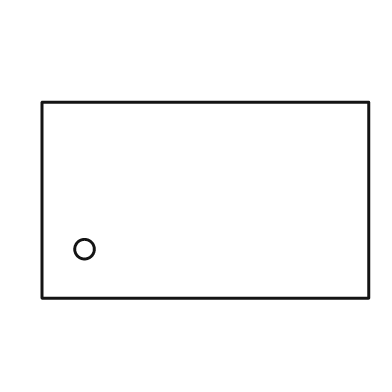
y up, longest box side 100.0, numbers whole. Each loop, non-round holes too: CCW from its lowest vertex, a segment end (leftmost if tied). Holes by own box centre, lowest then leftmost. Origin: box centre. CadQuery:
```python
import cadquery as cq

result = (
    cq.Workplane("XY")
    .moveTo(-50.0, -30.0)
    .lineTo(50.0, -30.0)
    .lineTo(50.0, 30.0)
    .lineTo(-50.0, 30.0)
    .close()
    .moveTo(-37.0, -15.0)
    .circle(3.0)
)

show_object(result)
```